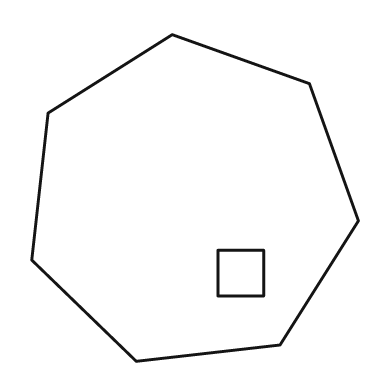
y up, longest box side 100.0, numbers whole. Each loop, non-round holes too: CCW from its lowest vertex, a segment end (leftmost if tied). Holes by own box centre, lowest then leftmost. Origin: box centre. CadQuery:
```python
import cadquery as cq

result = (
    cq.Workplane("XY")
    .moveTo(-18.0, -50.0)
    .lineTo(26.0, -45.0)
    .lineTo(50.0, -7.0)
    .lineTo(35.0, 35.0)
    .lineTo(-7.0, 50.0)
    .lineTo(-45.0, 26.0)
    .lineTo(-50.0, -19.0)
    .close()
    .moveTo(7.0, -30.0)
    .lineTo(21.0, -30.0)
    .lineTo(21.0, -16.0)
    .lineTo(7.0, -16.0)
    .close()
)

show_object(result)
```